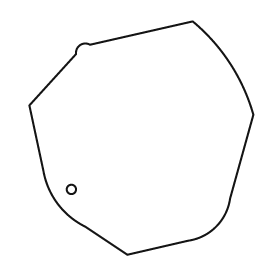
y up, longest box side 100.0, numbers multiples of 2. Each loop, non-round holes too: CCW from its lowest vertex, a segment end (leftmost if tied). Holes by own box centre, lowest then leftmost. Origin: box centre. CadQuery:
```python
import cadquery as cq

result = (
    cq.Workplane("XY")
    .moveTo(-6.0, -50.0)
    .lineTo(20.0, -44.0)
    .threePointArc((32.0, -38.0), (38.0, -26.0))
    .lineTo(48.0, 10.0)
    .threePointArc((38.0, 32.0), (22.0, 50.0))
    .lineTo(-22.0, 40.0)
    .threePointArc((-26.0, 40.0), (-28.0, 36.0))
    .lineTo(-48.0, 14.0)
    .lineTo(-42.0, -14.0)
    .threePointArc((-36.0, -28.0), (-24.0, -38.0))
    .close()
    .moveTo(-30.0, -22.0)
    .circle(2.0)
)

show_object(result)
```